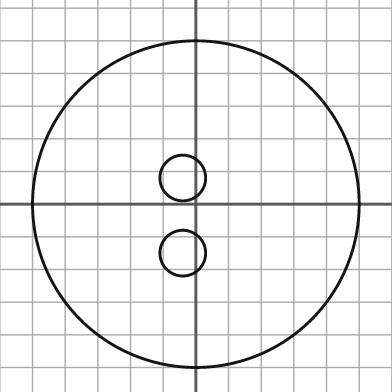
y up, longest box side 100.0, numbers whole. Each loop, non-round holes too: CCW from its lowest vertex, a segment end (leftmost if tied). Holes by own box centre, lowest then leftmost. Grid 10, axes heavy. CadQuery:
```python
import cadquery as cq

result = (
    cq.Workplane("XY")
    .moveTo(0.0, 0.0)
    .circle(50.0)
    .moveTo(-4.0, -15.0)
    .circle(7.0)
    .moveTo(-4.0, 8.0)
    .circle(7.0)
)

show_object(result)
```